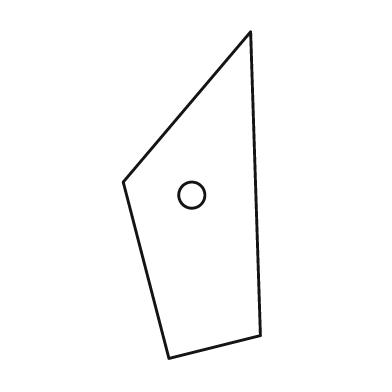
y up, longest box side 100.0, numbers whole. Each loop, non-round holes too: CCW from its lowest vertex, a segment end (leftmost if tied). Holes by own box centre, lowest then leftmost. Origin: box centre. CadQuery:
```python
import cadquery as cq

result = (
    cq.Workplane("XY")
    .moveTo(-7.0, -50.0)
    .lineTo(21.0, -43.0)
    .lineTo(18.0, 50.0)
    .lineTo(-21.0, 4.0)
    .close()
    .moveTo(0.0, 0.0)
    .circle(4.0)
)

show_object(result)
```